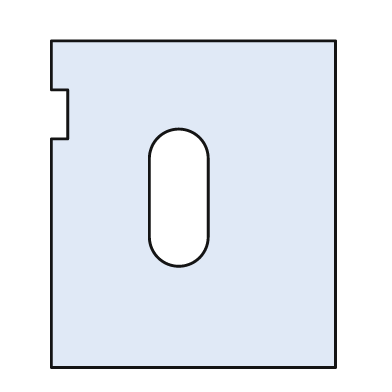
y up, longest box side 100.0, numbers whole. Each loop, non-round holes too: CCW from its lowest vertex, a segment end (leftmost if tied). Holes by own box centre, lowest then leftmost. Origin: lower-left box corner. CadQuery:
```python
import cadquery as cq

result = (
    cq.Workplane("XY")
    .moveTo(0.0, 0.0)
    .lineTo(87.0, 0.0)
    .lineTo(87.0, 100.0)
    .lineTo(0.0, 100.0)
    .lineTo(0.0, 85.0)
    .lineTo(5.0, 85.0)
    .lineTo(5.0, 70.0)
    .lineTo(0.0, 70.0)
    .close()
    .moveTo(30.0, 40.0)
    .threePointArc((39.0, 31.0), (48.0, 40.0))
    .lineTo(48.0, 64.0)
    .threePointArc((39.0, 73.0), (30.0, 64.0))
    .close()
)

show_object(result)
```